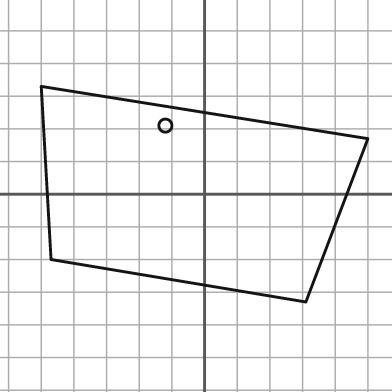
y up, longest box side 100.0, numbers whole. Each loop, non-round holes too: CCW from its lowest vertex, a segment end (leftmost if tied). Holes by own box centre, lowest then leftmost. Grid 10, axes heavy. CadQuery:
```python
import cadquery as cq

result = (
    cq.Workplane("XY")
    .moveTo(31.0, -33.0)
    .lineTo(50.0, 17.0)
    .lineTo(-50.0, 33.0)
    .lineTo(-47.0, -20.0)
    .close()
    .moveTo(-12.0, 21.0)
    .circle(2.0)
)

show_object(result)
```